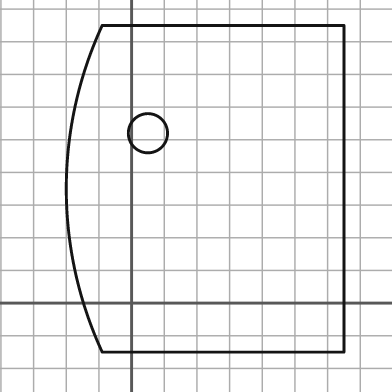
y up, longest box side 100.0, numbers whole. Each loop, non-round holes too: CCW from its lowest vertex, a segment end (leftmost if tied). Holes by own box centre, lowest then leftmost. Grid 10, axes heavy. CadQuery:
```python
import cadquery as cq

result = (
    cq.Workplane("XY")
    .moveTo(-9.0, -15.0)
    .lineTo(65.0, -15.0)
    .lineTo(65.0, 85.0)
    .lineTo(-9.0, 85.0)
    .threePointArc((-20.0, 35.0), (-9.0, -15.0))
    .close()
    .moveTo(5.0, 52.0)
    .circle(6.0)
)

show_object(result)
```